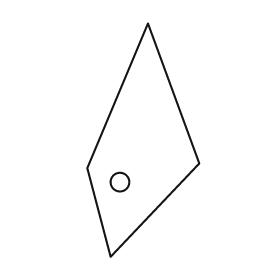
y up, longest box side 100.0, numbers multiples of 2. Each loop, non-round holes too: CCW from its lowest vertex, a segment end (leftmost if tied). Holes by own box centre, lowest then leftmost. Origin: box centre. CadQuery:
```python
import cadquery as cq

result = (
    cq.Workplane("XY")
    .moveTo(-14.0, -50.0)
    .lineTo(24.0, -10.0)
    .lineTo(2.0, 50.0)
    .lineTo(-24.0, -12.0)
    .close()
    .moveTo(-10.0, -18.0)
    .circle(4.0)
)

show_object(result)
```